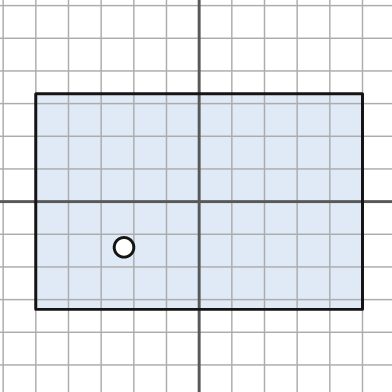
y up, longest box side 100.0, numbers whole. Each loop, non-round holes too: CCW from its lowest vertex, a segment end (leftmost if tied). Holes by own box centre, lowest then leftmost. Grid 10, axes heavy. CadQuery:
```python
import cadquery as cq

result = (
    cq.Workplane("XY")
    .moveTo(-50.0, -33.0)
    .lineTo(50.0, -33.0)
    .lineTo(50.0, 33.0)
    .lineTo(-50.0, 33.0)
    .close()
    .moveTo(-23.0, -14.0)
    .circle(3.0)
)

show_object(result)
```